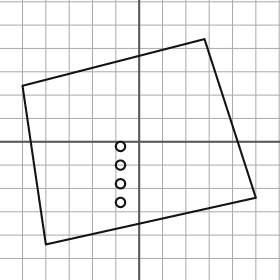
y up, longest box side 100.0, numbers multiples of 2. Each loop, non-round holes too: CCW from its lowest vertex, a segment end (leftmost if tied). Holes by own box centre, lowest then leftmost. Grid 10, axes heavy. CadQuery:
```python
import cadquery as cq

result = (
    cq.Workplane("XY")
    .moveTo(-40.0, -44.0)
    .lineTo(50.0, -24.0)
    .lineTo(28.0, 44.0)
    .lineTo(-50.0, 24.0)
    .close()
    .moveTo(-8.0, -26.0)
    .circle(2.0)
    .moveTo(-8.0, -18.0)
    .circle(2.0)
    .moveTo(-8.0, -10.0)
    .circle(2.0)
    .moveTo(-8.0, -2.0)
    .circle(2.0)
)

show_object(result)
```